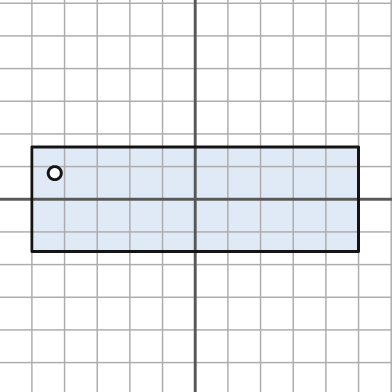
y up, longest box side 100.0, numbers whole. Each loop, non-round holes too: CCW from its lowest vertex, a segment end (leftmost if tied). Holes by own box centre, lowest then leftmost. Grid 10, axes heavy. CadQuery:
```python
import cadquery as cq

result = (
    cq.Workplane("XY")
    .moveTo(-50.0, -16.0)
    .lineTo(50.0, -16.0)
    .lineTo(50.0, 16.0)
    .lineTo(-50.0, 16.0)
    .close()
    .moveTo(-43.0, 8.0)
    .circle(2.0)
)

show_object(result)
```